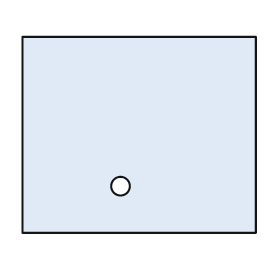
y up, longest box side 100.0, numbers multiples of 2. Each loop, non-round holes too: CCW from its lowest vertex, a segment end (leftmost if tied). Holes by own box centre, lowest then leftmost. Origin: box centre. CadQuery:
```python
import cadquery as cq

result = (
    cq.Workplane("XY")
    .moveTo(-50.0, -42.0)
    .lineTo(50.0, -42.0)
    .lineTo(50.0, 42.0)
    .lineTo(-50.0, 42.0)
    .close()
    .moveTo(-8.0, -22.0)
    .circle(4.0)
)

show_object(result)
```